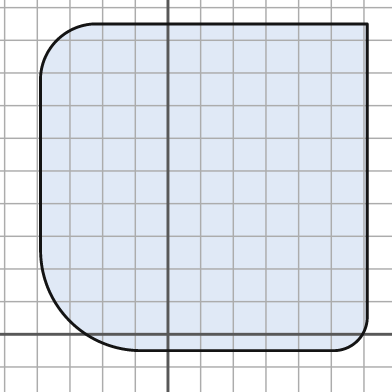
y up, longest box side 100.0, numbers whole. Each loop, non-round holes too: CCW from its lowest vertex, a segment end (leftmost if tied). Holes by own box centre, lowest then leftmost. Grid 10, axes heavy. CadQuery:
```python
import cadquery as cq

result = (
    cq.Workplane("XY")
    .moveTo(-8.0, -5.0)
    .lineTo(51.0, -5.0)
    .threePointArc((58.0, -2.0), (61.0, 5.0))
    .lineTo(61.0, 95.0)
    .lineTo(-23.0, 95.0)
    .threePointArc((-34.0, 90.0), (-39.0, 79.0))
    .lineTo(-39.0, 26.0)
    .threePointArc((-30.0, 4.0), (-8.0, -5.0))
    .close()
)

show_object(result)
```